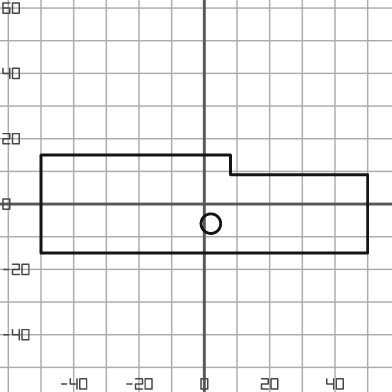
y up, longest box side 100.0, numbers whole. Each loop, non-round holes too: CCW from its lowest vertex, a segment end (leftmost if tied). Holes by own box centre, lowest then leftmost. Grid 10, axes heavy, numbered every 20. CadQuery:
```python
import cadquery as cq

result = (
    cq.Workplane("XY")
    .moveTo(-50.0, -15.0)
    .lineTo(50.0, -15.0)
    .lineTo(50.0, 9.0)
    .lineTo(8.0, 9.0)
    .lineTo(8.0, 15.0)
    .lineTo(-50.0, 15.0)
    .close()
    .moveTo(2.0, -6.0)
    .circle(3.0)
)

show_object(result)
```